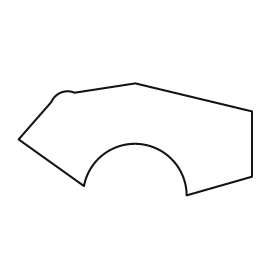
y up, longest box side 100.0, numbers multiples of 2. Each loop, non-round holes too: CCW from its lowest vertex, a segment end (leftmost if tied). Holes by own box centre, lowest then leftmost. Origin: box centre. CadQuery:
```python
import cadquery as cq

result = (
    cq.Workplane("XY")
    .moveTo(22.0, -24.0)
    .lineTo(50.0, -16.0)
    .lineTo(50.0, 12.0)
    .lineTo(0.0, 24.0)
    .lineTo(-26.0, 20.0)
    .threePointArc((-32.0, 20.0), (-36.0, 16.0))
    .lineTo(-50.0, 0.0)
    .lineTo(-22.0, -20.0)
    .threePointArc((2.0, -2.0), (22.0, -24.0))
    .close()
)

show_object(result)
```